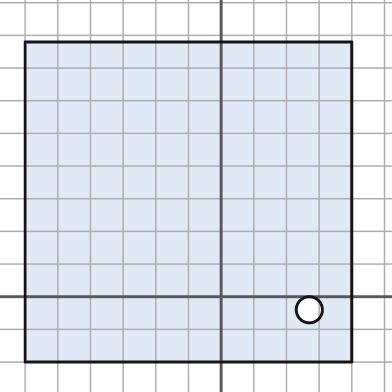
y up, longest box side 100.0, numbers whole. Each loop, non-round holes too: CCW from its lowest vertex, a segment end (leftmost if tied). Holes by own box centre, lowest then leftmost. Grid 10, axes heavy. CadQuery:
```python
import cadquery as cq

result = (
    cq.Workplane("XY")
    .moveTo(-60.0, -20.0)
    .lineTo(40.0, -20.0)
    .lineTo(40.0, 78.0)
    .lineTo(-60.0, 78.0)
    .close()
    .moveTo(27.0, -4.0)
    .circle(4.0)
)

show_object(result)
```